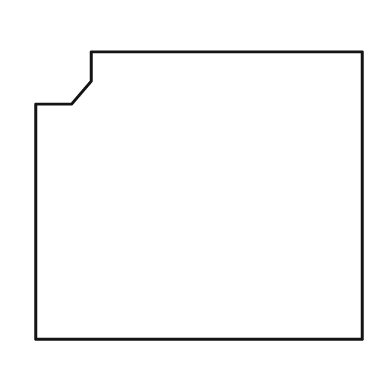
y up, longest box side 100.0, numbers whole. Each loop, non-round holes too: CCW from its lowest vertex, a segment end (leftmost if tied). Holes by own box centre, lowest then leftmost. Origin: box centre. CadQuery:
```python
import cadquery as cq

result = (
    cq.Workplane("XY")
    .moveTo(-50.0, -44.0)
    .lineTo(50.0, -44.0)
    .lineTo(50.0, 44.0)
    .lineTo(-33.0, 44.0)
    .lineTo(-33.0, 35.0)
    .lineTo(-39.0, 28.0)
    .lineTo(-50.0, 28.0)
    .close()
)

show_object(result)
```